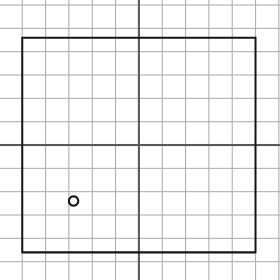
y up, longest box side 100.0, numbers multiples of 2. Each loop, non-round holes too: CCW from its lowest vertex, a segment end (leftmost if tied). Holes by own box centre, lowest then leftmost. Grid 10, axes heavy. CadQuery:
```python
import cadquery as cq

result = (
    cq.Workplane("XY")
    .moveTo(-50.0, -46.0)
    .lineTo(50.0, -46.0)
    .lineTo(50.0, 46.0)
    .lineTo(-50.0, 46.0)
    .close()
    .moveTo(-28.0, -24.0)
    .circle(2.0)
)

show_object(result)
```